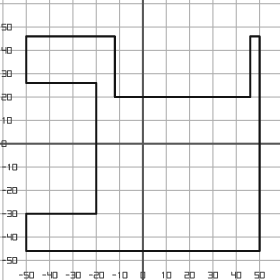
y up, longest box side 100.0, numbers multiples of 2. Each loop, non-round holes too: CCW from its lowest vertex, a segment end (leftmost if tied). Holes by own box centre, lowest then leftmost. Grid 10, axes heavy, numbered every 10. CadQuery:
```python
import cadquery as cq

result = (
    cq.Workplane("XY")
    .moveTo(-50.0, -46.0)
    .lineTo(50.0, -46.0)
    .lineTo(50.0, 46.0)
    .lineTo(46.0, 46.0)
    .lineTo(46.0, 20.0)
    .lineTo(-12.0, 20.0)
    .lineTo(-12.0, 46.0)
    .lineTo(-50.0, 46.0)
    .lineTo(-50.0, 26.0)
    .lineTo(-20.0, 26.0)
    .lineTo(-20.0, -30.0)
    .lineTo(-50.0, -30.0)
    .close()
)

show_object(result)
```